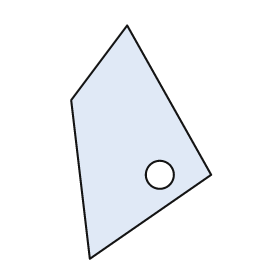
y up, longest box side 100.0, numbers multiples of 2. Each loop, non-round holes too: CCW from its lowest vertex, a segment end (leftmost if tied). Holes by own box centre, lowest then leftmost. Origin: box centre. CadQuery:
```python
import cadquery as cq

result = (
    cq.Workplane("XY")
    .moveTo(-22.0, -50.0)
    .lineTo(30.0, -14.0)
    .lineTo(-6.0, 50.0)
    .lineTo(-30.0, 18.0)
    .close()
    .moveTo(8.0, -14.0)
    .circle(6.0)
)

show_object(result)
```